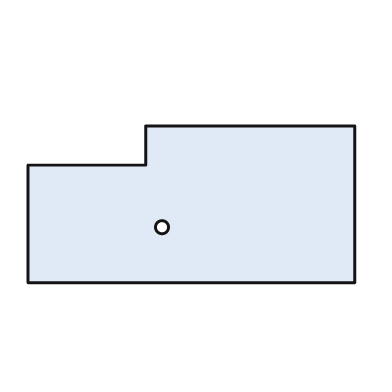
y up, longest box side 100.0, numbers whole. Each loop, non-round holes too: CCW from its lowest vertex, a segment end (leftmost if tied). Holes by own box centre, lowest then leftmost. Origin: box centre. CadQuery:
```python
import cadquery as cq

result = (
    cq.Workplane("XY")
    .moveTo(-50.0, -24.0)
    .lineTo(50.0, -24.0)
    .lineTo(50.0, 24.0)
    .lineTo(-14.0, 24.0)
    .lineTo(-14.0, 12.0)
    .lineTo(-50.0, 12.0)
    .close()
    .moveTo(-9.0, -7.0)
    .circle(2.0)
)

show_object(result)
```